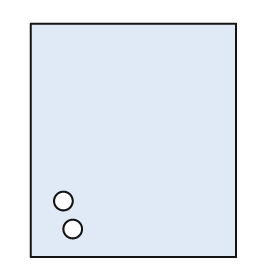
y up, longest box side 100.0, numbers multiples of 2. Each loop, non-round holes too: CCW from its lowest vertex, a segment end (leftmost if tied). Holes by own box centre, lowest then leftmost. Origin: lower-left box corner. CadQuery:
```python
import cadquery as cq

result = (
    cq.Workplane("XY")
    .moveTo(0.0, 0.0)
    .lineTo(88.0, 0.0)
    .lineTo(88.0, 100.0)
    .lineTo(0.0, 100.0)
    .close()
    .moveTo(18.0, 12.0)
    .circle(4.0)
    .moveTo(14.0, 24.0)
    .circle(4.0)
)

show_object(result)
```